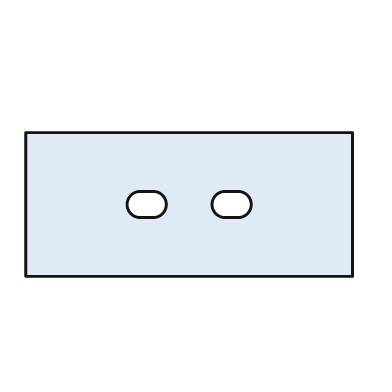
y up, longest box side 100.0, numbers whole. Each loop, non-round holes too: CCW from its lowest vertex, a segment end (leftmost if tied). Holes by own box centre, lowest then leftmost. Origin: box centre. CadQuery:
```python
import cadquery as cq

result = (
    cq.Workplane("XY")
    .moveTo(-50.0, -22.0)
    .lineTo(50.0, -22.0)
    .lineTo(50.0, 22.0)
    .lineTo(-50.0, 22.0)
    .close()
    .moveTo(-15.0, -4.0)
    .lineTo(-11.0, -4.0)
    .threePointArc((-7.0, 0.0), (-11.0, 4.0))
    .lineTo(-15.0, 4.0)
    .threePointArc((-19.0, 0.0), (-15.0, -4.0))
    .close()
    .moveTo(11.0, -4.0)
    .lineTo(15.0, -4.0)
    .threePointArc((19.0, 0.0), (15.0, 4.0))
    .lineTo(11.0, 4.0)
    .threePointArc((7.0, 0.0), (11.0, -4.0))
    .close()
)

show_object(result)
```